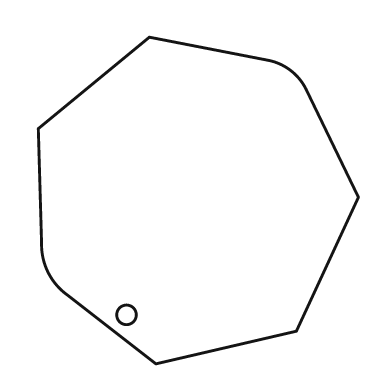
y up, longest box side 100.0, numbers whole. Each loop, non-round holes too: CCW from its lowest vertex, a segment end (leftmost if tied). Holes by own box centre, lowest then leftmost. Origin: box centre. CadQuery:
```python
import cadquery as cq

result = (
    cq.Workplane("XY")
    .moveTo(-13.0, -50.0)
    .lineTo(30.0, -40.0)
    .lineTo(49.0, 1.0)
    .lineTo(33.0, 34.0)
    .threePointArc((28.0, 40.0), (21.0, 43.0))
    .lineTo(-15.0, 50.0)
    .lineTo(-49.0, 22.0)
    .lineTo(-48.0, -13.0)
    .threePointArc((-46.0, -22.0), (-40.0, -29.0))
    .close()
    .moveTo(-22.0, -35.0)
    .circle(3.0)
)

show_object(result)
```